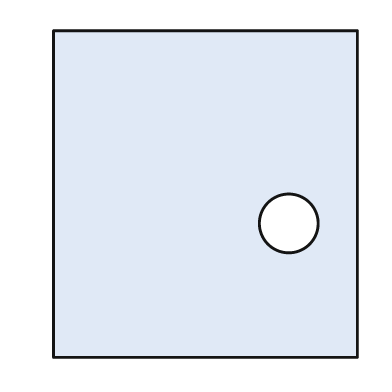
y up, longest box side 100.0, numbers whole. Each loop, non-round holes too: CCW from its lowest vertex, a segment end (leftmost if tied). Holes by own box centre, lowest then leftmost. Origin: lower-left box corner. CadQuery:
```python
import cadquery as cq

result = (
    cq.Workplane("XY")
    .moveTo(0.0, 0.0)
    .lineTo(93.0, 0.0)
    .lineTo(93.0, 100.0)
    .lineTo(0.0, 100.0)
    .close()
    .moveTo(72.0, 41.0)
    .circle(9.0)
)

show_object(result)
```